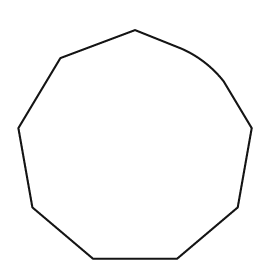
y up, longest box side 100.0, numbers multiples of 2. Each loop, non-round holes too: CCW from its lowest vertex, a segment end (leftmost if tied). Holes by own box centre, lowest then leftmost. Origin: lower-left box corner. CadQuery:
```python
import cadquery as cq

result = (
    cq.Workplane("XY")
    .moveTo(32.0, 0.0)
    .lineTo(68.0, 0.0)
    .lineTo(94.0, 22.0)
    .lineTo(100.0, 56.0)
    .lineTo(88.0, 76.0)
    .threePointArc((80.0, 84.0), (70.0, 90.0))
    .lineTo(50.0, 98.0)
    .lineTo(18.0, 86.0)
    .lineTo(0.0, 56.0)
    .lineTo(6.0, 22.0)
    .close()
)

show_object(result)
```